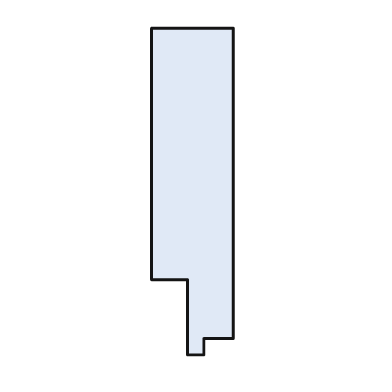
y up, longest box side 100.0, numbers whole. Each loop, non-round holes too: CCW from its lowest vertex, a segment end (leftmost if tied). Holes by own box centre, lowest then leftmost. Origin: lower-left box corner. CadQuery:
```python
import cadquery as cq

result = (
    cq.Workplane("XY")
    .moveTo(11.0, 0.0)
    .lineTo(16.0, 0.0)
    .lineTo(16.0, 5.0)
    .lineTo(25.0, 5.0)
    .lineTo(25.0, 100.0)
    .lineTo(0.0, 100.0)
    .lineTo(0.0, 23.0)
    .lineTo(11.0, 23.0)
    .close()
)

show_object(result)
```